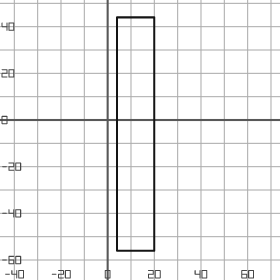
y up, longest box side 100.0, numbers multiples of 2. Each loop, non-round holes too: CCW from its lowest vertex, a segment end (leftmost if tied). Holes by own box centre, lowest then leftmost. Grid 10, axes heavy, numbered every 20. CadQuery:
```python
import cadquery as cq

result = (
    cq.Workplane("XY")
    .moveTo(4.0, -56.0)
    .lineTo(20.0, -56.0)
    .lineTo(20.0, 44.0)
    .lineTo(4.0, 44.0)
    .close()
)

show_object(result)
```